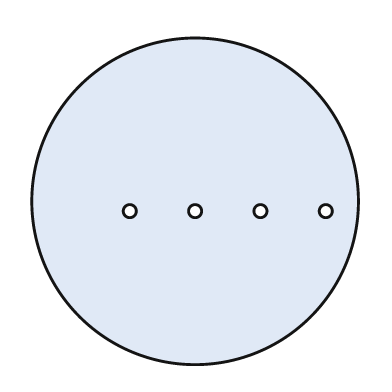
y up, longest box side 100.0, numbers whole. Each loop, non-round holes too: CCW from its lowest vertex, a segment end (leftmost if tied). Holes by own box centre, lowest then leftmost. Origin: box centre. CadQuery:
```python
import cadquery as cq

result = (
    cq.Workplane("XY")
    .moveTo(0.0, 0.0)
    .circle(50.0)
    .moveTo(-20.0, -3.0)
    .circle(2.0)
    .moveTo(0.0, -3.0)
    .circle(2.0)
    .moveTo(20.0, -3.0)
    .circle(2.0)
    .moveTo(40.0, -3.0)
    .circle(2.0)
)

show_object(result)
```